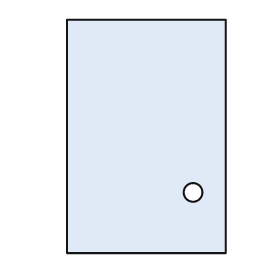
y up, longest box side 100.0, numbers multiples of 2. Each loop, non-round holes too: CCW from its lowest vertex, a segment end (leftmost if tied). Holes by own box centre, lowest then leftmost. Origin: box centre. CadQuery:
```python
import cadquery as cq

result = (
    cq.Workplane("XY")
    .moveTo(-34.0, -50.0)
    .lineTo(34.0, -50.0)
    .lineTo(34.0, 50.0)
    .lineTo(-34.0, 50.0)
    .close()
    .moveTo(20.0, -24.0)
    .circle(4.0)
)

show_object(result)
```